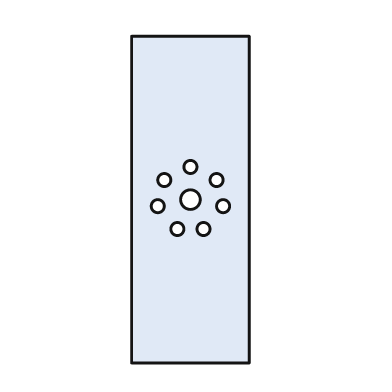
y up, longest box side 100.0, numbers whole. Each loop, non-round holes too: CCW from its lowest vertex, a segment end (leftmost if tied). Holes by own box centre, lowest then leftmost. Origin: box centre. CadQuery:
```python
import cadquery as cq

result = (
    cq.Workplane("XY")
    .moveTo(-18.0, -50.0)
    .lineTo(18.0, -50.0)
    .lineTo(18.0, 50.0)
    .lineTo(-18.0, 50.0)
    .close()
    .moveTo(-4.0, -9.0)
    .circle(2.0)
    .moveTo(4.0, -9.0)
    .circle(2.0)
    .moveTo(-10.0, -2.0)
    .circle(2.0)
    .moveTo(10.0, -2.0)
    .circle(2.0)
    .moveTo(0.0, 0.0)
    .circle(3.0)
    .moveTo(-8.0, 6.0)
    .circle(2.0)
    .moveTo(8.0, 6.0)
    .circle(2.0)
    .moveTo(0.0, 10.0)
    .circle(2.0)
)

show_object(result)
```